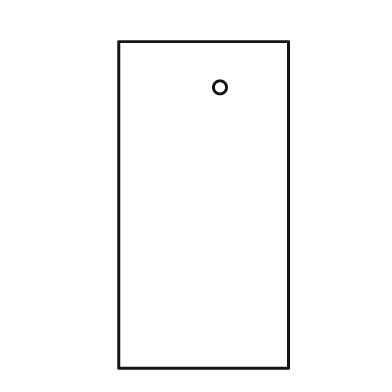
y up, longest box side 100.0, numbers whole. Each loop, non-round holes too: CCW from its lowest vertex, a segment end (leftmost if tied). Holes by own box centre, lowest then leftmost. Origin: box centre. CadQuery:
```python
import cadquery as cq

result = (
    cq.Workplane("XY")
    .moveTo(-26.0, -50.0)
    .lineTo(26.0, -50.0)
    .lineTo(26.0, 50.0)
    .lineTo(-26.0, 50.0)
    .close()
    .moveTo(5.0, 36.0)
    .circle(2.0)
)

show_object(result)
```